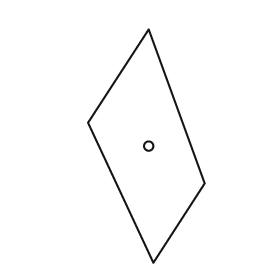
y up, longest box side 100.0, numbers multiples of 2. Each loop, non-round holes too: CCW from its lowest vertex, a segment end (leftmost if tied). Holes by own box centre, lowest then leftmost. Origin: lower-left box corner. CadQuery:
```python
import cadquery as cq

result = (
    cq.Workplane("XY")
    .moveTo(28.0, 0.0)
    .lineTo(50.0, 34.0)
    .lineTo(26.0, 100.0)
    .lineTo(0.0, 60.0)
    .close()
    .moveTo(26.0, 50.0)
    .circle(2.0)
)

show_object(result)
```